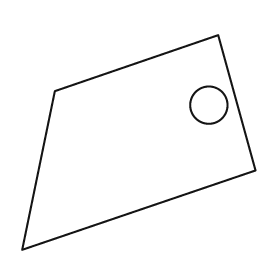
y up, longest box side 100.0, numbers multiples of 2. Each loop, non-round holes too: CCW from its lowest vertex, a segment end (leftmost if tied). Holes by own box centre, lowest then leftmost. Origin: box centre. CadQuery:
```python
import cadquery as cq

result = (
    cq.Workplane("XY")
    .moveTo(-50.0, -46.0)
    .lineTo(50.0, -12.0)
    .lineTo(34.0, 46.0)
    .lineTo(-36.0, 22.0)
    .close()
    .moveTo(30.0, 16.0)
    .circle(8.0)
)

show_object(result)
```